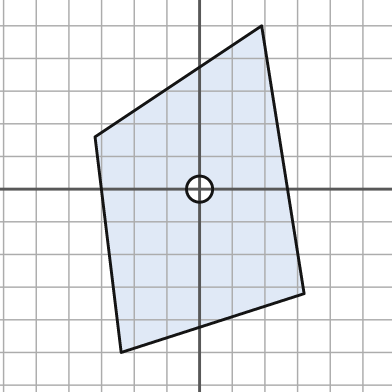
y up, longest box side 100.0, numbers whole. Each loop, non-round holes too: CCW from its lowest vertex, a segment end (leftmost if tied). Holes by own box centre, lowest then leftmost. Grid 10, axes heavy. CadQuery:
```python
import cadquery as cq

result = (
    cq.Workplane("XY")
    .moveTo(-24.0, -50.0)
    .lineTo(32.0, -32.0)
    .lineTo(19.0, 50.0)
    .lineTo(-32.0, 16.0)
    .close()
    .moveTo(0.0, 0.0)
    .circle(4.0)
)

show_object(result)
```